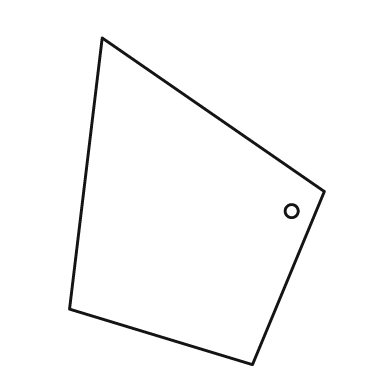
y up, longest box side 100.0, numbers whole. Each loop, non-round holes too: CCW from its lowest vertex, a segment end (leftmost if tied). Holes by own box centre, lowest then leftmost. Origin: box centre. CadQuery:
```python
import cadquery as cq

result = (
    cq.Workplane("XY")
    .moveTo(17.0, -50.0)
    .lineTo(39.0, 3.0)
    .lineTo(-29.0, 50.0)
    .lineTo(-39.0, -33.0)
    .close()
    .moveTo(29.0, -3.0)
    .circle(2.0)
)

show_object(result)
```